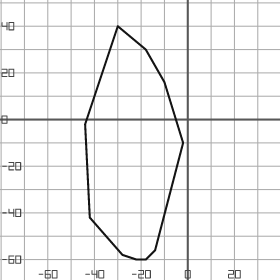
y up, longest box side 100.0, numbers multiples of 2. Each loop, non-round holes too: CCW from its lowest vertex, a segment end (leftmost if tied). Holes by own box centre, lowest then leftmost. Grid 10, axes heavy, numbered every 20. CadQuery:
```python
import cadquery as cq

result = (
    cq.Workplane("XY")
    .moveTo(-22.0, -60.0)
    .lineTo(-18.0, -60.0)
    .lineTo(-14.0, -56.0)
    .lineTo(-2.0, -10.0)
    .lineTo(-10.0, 16.0)
    .lineTo(-18.0, 30.0)
    .lineTo(-30.0, 40.0)
    .lineTo(-44.0, -2.0)
    .lineTo(-42.0, -42.0)
    .lineTo(-28.0, -58.0)
    .close()
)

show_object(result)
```